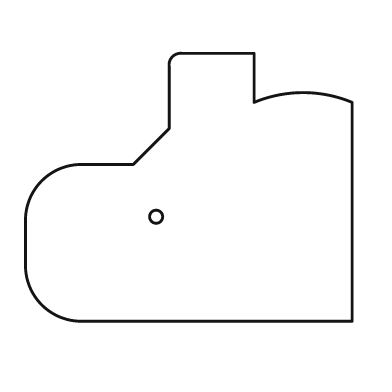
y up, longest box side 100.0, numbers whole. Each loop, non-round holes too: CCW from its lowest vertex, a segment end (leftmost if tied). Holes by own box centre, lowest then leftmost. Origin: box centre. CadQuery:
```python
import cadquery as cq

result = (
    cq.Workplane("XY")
    .moveTo(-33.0, -41.0)
    .lineTo(50.0, -41.0)
    .lineTo(50.0, 26.0)
    .threePointArc((35.0, 29.0), (20.0, 26.0))
    .lineTo(20.0, 41.0)
    .lineTo(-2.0, 41.0)
    .threePointArc((-5.0, 40.0), (-6.0, 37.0))
    .lineTo(-6.0, 18.0)
    .lineTo(-17.0, 7.0)
    .lineTo(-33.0, 7.0)
    .threePointArc((-45.0, 2.0), (-50.0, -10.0))
    .lineTo(-50.0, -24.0)
    .threePointArc((-45.0, -36.0), (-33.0, -41.0))
    .close()
    .moveTo(-10.0, -9.0)
    .circle(2.0)
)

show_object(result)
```